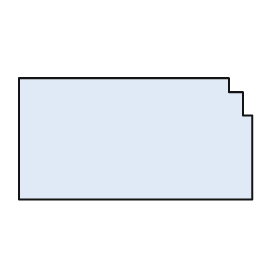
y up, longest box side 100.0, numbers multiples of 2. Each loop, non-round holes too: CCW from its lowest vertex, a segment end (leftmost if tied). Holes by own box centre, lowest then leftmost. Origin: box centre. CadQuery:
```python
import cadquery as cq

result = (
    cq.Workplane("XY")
    .moveTo(-50.0, -26.0)
    .lineTo(50.0, -26.0)
    .lineTo(50.0, 10.0)
    .lineTo(46.0, 10.0)
    .lineTo(46.0, 20.0)
    .lineTo(40.0, 20.0)
    .lineTo(40.0, 26.0)
    .lineTo(-50.0, 26.0)
    .close()
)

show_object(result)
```